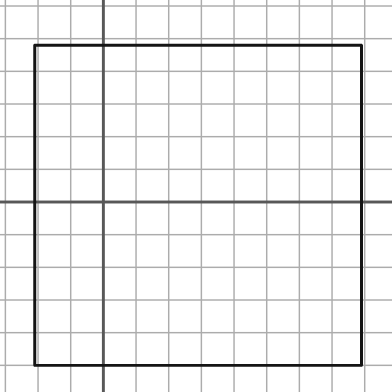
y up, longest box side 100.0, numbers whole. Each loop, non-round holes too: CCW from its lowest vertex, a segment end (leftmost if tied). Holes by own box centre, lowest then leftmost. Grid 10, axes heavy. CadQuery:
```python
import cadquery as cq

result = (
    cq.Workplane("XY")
    .moveTo(-21.0, -50.0)
    .lineTo(79.0, -50.0)
    .lineTo(79.0, 48.0)
    .lineTo(-21.0, 48.0)
    .close()
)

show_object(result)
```